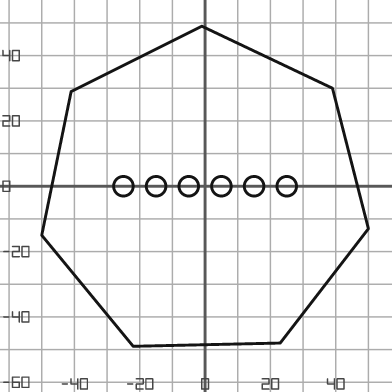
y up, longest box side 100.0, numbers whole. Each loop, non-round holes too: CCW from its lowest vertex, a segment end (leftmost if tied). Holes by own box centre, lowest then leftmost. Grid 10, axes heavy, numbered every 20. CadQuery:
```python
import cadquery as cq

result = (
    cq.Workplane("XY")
    .moveTo(-22.0, -49.0)
    .lineTo(23.0, -48.0)
    .lineTo(50.0, -13.0)
    .lineTo(39.0, 30.0)
    .lineTo(-1.0, 49.0)
    .lineTo(-41.0, 29.0)
    .lineTo(-50.0, -15.0)
    .close()
    .moveTo(-25.0, 0.0)
    .circle(3.0)
    .moveTo(-15.0, 0.0)
    .circle(3.0)
    .moveTo(-5.0, 0.0)
    .circle(3.0)
    .moveTo(5.0, 0.0)
    .circle(3.0)
    .moveTo(15.0, 0.0)
    .circle(3.0)
    .moveTo(25.0, 0.0)
    .circle(3.0)
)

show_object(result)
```